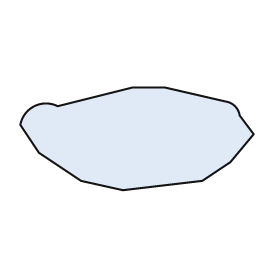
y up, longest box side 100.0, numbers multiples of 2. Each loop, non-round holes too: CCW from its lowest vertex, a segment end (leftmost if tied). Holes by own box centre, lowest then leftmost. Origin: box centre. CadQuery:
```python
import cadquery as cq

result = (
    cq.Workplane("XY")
    .moveTo(-6.0, -22.0)
    .lineTo(28.0, -18.0)
    .lineTo(40.0, -10.0)
    .lineTo(50.0, 2.0)
    .lineTo(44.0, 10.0)
    .threePointArc((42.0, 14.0), (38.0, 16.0))
    .lineTo(12.0, 22.0)
    .lineTo(-2.0, 22.0)
    .lineTo(-34.0, 14.0)
    .threePointArc((-44.0, 14.0), (-50.0, 6.0))
    .lineTo(-42.0, -6.0)
    .lineTo(-24.0, -18.0)
    .close()
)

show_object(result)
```